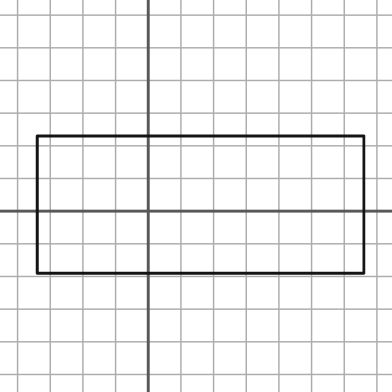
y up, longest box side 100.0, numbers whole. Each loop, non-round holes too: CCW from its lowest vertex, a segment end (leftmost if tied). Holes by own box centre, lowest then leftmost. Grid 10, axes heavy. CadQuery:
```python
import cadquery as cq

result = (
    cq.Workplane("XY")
    .moveTo(-34.0, -19.0)
    .lineTo(66.0, -19.0)
    .lineTo(66.0, 23.0)
    .lineTo(-34.0, 23.0)
    .close()
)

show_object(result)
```